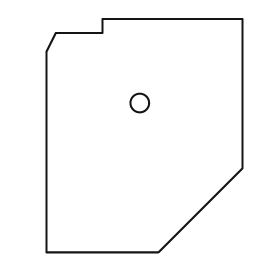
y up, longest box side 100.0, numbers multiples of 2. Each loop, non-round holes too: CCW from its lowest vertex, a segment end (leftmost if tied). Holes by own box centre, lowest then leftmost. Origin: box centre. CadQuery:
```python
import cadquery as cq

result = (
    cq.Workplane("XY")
    .moveTo(-42.0, -50.0)
    .lineTo(6.0, -50.0)
    .lineTo(42.0, -14.0)
    .lineTo(42.0, 50.0)
    .lineTo(-18.0, 50.0)
    .lineTo(-18.0, 44.0)
    .lineTo(-38.0, 44.0)
    .lineTo(-42.0, 36.0)
    .close()
    .moveTo(-2.0, 14.0)
    .circle(4.0)
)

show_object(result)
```